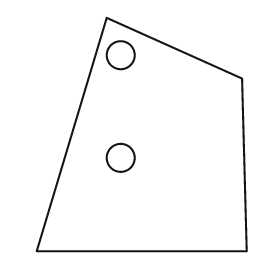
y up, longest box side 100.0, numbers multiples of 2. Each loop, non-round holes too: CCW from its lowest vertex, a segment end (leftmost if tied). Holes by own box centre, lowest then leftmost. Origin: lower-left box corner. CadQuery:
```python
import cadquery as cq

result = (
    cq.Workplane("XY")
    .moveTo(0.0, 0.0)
    .lineTo(90.0, 0.0)
    .lineTo(88.0, 74.0)
    .lineTo(30.0, 100.0)
    .close()
    .moveTo(36.0, 40.0)
    .circle(6.0)
    .moveTo(36.0, 84.0)
    .circle(6.0)
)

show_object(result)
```